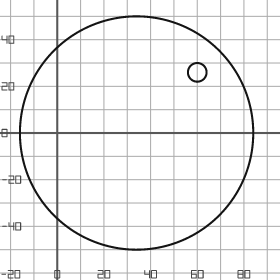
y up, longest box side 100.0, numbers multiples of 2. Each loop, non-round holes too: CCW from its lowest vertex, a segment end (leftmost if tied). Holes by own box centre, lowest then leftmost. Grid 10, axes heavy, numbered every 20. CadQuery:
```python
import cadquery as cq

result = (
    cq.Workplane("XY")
    .moveTo(34.0, 0.0)
    .circle(50.0)
    .moveTo(60.0, 26.0)
    .circle(4.0)
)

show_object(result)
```